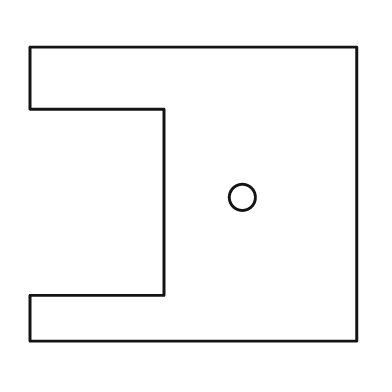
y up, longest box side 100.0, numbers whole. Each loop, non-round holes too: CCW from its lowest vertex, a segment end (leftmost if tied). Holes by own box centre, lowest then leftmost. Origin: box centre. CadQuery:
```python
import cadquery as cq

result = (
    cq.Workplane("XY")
    .moveTo(-50.0, -45.0)
    .lineTo(50.0, -45.0)
    .lineTo(50.0, 45.0)
    .lineTo(-50.0, 45.0)
    .lineTo(-50.0, 26.0)
    .lineTo(-9.0, 26.0)
    .lineTo(-9.0, -31.0)
    .lineTo(-50.0, -31.0)
    .close()
    .moveTo(15.0, -1.0)
    .circle(4.0)
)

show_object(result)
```